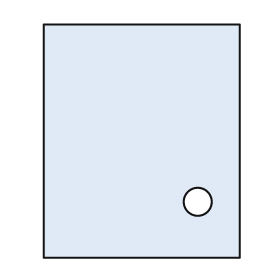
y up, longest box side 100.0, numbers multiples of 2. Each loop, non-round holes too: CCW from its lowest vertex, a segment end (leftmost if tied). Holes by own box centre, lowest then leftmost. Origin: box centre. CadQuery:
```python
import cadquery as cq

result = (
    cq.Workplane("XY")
    .moveTo(-42.0, -50.0)
    .lineTo(42.0, -50.0)
    .lineTo(42.0, 50.0)
    .lineTo(-42.0, 50.0)
    .close()
    .moveTo(24.0, -26.0)
    .circle(6.0)
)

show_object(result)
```